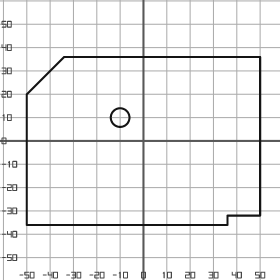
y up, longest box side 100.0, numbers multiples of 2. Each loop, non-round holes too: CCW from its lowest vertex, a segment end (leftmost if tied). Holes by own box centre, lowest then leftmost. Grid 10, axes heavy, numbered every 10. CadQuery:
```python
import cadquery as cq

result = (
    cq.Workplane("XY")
    .moveTo(-50.0, -36.0)
    .lineTo(36.0, -36.0)
    .lineTo(36.0, -32.0)
    .lineTo(50.0, -32.0)
    .lineTo(50.0, 36.0)
    .lineTo(-34.0, 36.0)
    .lineTo(-50.0, 20.0)
    .close()
    .moveTo(-10.0, 10.0)
    .circle(4.0)
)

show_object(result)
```